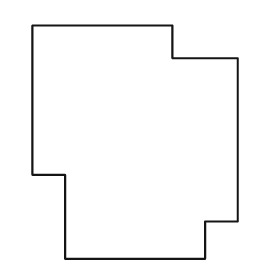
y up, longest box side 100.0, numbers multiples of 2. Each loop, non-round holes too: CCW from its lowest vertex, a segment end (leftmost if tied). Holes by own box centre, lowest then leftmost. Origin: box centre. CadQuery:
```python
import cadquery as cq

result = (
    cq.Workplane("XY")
    .moveTo(-30.0, -50.0)
    .lineTo(30.0, -50.0)
    .lineTo(30.0, -34.0)
    .lineTo(44.0, -34.0)
    .lineTo(44.0, 36.0)
    .lineTo(16.0, 36.0)
    .lineTo(16.0, 50.0)
    .lineTo(-44.0, 50.0)
    .lineTo(-44.0, -14.0)
    .lineTo(-30.0, -14.0)
    .close()
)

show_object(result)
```